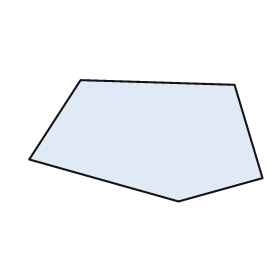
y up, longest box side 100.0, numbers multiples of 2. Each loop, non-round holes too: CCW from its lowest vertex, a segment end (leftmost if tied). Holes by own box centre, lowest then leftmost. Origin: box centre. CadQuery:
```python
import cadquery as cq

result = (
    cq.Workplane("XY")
    .moveTo(14.0, -26.0)
    .lineTo(50.0, -16.0)
    .lineTo(38.0, 24.0)
    .lineTo(-28.0, 26.0)
    .lineTo(-50.0, -8.0)
    .close()
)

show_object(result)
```